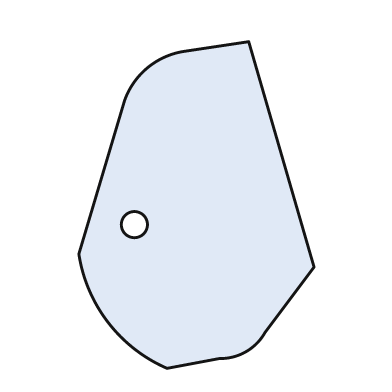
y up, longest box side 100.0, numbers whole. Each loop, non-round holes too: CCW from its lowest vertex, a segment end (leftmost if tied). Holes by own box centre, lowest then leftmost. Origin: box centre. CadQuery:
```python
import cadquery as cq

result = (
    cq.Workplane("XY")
    .moveTo(-9.0, -50.0)
    .lineTo(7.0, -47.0)
    .threePointArc((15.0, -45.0), (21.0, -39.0))
    .lineTo(36.0, -19.0)
    .lineTo(16.0, 50.0)
    .lineTo(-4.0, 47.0)
    .threePointArc((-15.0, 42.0), (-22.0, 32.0))
    .lineTo(-36.0, -15.0)
    .threePointArc((-27.0, -36.0), (-9.0, -50.0))
    .close()
    .moveTo(-19.0, -6.0)
    .circle(4.0)
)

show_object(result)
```